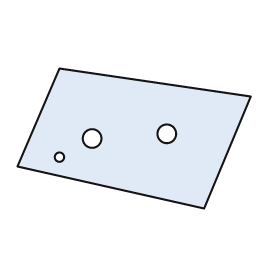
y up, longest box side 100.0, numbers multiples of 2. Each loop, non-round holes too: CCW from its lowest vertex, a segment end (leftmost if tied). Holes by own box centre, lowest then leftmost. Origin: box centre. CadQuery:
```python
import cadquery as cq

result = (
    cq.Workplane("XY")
    .moveTo(30.0, -30.0)
    .lineTo(50.0, 18.0)
    .lineTo(-32.0, 30.0)
    .lineTo(-50.0, -12.0)
    .close()
    .moveTo(-32.0, -8.0)
    .circle(2.0)
    .moveTo(-18.0, 0.0)
    .circle(4.0)
    .moveTo(14.0, 2.0)
    .circle(4.0)
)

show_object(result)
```